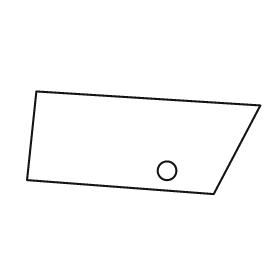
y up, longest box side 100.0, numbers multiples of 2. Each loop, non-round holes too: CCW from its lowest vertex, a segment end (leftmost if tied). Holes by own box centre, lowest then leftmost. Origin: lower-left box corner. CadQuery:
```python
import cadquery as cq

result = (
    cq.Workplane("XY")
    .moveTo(80.0, 0.0)
    .lineTo(100.0, 38.0)
    .lineTo(4.0, 44.0)
    .lineTo(0.0, 6.0)
    .close()
    .moveTo(60.0, 10.0)
    .circle(4.0)
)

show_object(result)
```